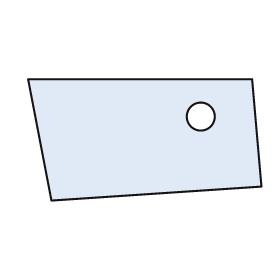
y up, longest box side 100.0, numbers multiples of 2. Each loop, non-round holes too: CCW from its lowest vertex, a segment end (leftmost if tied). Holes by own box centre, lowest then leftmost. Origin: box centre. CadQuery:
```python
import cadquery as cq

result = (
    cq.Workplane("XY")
    .moveTo(-40.0, -26.0)
    .lineTo(50.0, -20.0)
    .lineTo(46.0, 26.0)
    .lineTo(-50.0, 26.0)
    .close()
    .moveTo(24.0, 10.0)
    .circle(6.0)
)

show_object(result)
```